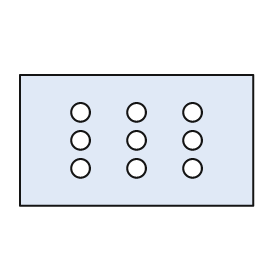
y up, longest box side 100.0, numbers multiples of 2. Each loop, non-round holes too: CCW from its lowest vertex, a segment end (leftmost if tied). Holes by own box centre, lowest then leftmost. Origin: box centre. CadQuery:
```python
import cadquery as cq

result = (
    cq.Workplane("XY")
    .moveTo(-50.0, -28.0)
    .lineTo(50.0, -28.0)
    .lineTo(50.0, 28.0)
    .lineTo(-50.0, 28.0)
    .close()
    .moveTo(-24.0, -12.0)
    .circle(4.0)
    .moveTo(0.0, -12.0)
    .circle(4.0)
    .moveTo(24.0, -12.0)
    .circle(4.0)
    .moveTo(-24.0, 0.0)
    .circle(4.0)
    .moveTo(0.0, 0.0)
    .circle(4.0)
    .moveTo(24.0, 0.0)
    .circle(4.0)
    .moveTo(-24.0, 12.0)
    .circle(4.0)
    .moveTo(0.0, 12.0)
    .circle(4.0)
    .moveTo(24.0, 12.0)
    .circle(4.0)
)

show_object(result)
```